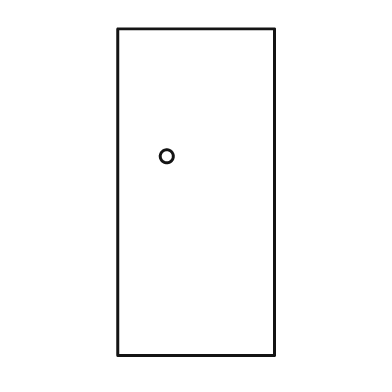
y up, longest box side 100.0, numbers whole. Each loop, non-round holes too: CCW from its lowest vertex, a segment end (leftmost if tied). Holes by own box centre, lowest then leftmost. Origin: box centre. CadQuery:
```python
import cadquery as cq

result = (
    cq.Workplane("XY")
    .moveTo(-24.0, -50.0)
    .lineTo(24.0, -50.0)
    .lineTo(24.0, 50.0)
    .lineTo(-24.0, 50.0)
    .close()
    .moveTo(-9.0, 11.0)
    .circle(2.0)
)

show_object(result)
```